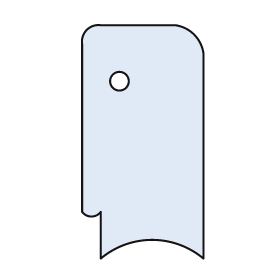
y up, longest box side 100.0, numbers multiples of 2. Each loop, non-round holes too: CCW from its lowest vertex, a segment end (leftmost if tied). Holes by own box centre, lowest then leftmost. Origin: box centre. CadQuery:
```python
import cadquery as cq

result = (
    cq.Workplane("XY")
    .moveTo(-18.0, -50.0)
    .threePointArc((4.0, -42.0), (26.0, -50.0))
    .lineTo(26.0, 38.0)
    .threePointArc((22.0, 46.0), (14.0, 50.0))
    .lineTo(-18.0, 50.0)
    .threePointArc((-24.0, 48.0), (-26.0, 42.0))
    .lineTo(-26.0, -30.0)
    .threePointArc((-22.0, -32.0), (-18.0, -30.0))
    .close()
    .moveTo(-10.0, 26.0)
    .circle(4.0)
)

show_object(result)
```